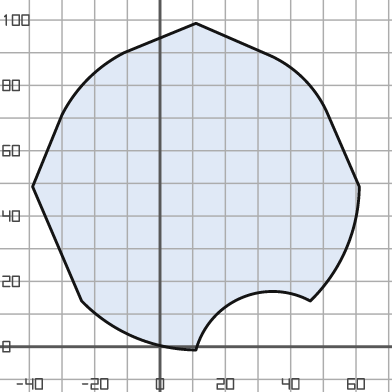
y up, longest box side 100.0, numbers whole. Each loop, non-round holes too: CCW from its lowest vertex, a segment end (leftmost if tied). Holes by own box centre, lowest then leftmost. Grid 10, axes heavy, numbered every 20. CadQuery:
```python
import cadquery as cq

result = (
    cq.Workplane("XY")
    .moveTo(11.0, -1.0)
    .threePointArc((25.0, 15.0), (46.0, 14.0))
    .threePointArc((57.0, 30.0), (61.0, 49.0))
    .lineTo(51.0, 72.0)
    .threePointArc((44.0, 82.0), (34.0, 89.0))
    .lineTo(11.0, 99.0)
    .lineTo(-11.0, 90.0)
    .threePointArc((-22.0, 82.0), (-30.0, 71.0))
    .lineTo(-39.0, 49.0)
    .lineTo(-24.0, 14.0)
    .threePointArc((-8.0, 3.0), (11.0, -1.0))
    .close()
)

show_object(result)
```